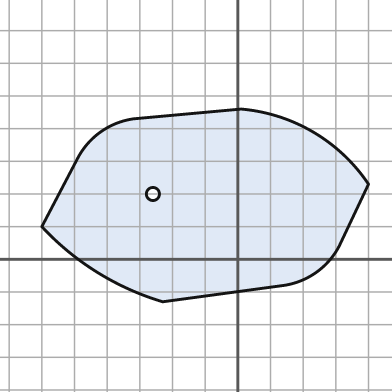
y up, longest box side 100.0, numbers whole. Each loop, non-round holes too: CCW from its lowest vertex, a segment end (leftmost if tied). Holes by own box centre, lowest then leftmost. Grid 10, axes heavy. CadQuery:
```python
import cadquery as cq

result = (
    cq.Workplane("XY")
    .moveTo(-23.0, -13.0)
    .lineTo(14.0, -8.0)
    .threePointArc((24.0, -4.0), (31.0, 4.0))
    .lineTo(40.0, 23.0)
    .threePointArc((23.0, 39.0), (1.0, 46.0))
    .lineTo(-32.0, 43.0)
    .threePointArc((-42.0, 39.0), (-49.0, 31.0))
    .lineTo(-60.0, 10.0)
    .threePointArc((-43.0, -4.0), (-23.0, -13.0))
    .close()
    .moveTo(-26.0, 20.0)
    .circle(2.0)
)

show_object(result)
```